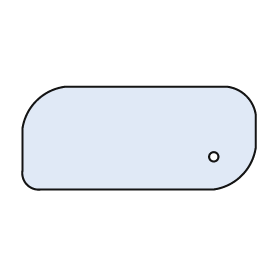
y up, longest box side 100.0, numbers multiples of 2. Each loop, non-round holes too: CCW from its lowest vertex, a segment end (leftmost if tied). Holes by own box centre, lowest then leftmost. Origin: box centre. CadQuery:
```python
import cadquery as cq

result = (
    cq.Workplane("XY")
    .moveTo(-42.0, -22.0)
    .lineTo(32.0, -22.0)
    .threePointArc((44.0, -16.0), (50.0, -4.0))
    .lineTo(50.0, 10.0)
    .threePointArc((46.0, 18.0), (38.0, 22.0))
    .lineTo(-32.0, 22.0)
    .threePointArc((-44.0, 16.0), (-50.0, 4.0))
    .lineTo(-50.0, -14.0)
    .threePointArc((-48.0, -20.0), (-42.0, -22.0))
    .close()
    .moveTo(32.0, -8.0)
    .circle(2.0)
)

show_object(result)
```